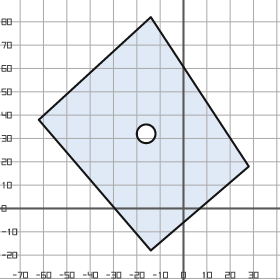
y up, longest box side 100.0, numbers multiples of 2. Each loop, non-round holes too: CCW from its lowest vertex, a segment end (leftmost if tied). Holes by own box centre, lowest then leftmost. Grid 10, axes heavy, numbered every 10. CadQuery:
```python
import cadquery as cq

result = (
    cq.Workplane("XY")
    .moveTo(-14.0, -18.0)
    .lineTo(28.0, 18.0)
    .lineTo(-14.0, 82.0)
    .lineTo(-62.0, 38.0)
    .close()
    .moveTo(-16.0, 32.0)
    .circle(4.0)
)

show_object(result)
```